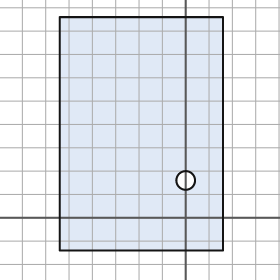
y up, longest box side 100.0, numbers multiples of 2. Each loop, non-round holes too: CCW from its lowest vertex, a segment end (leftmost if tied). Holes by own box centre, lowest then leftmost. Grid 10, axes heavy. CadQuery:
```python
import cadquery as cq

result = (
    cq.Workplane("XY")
    .moveTo(-54.0, -14.0)
    .lineTo(16.0, -14.0)
    .lineTo(16.0, 86.0)
    .lineTo(-54.0, 86.0)
    .close()
    .moveTo(0.0, 16.0)
    .circle(4.0)
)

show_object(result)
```